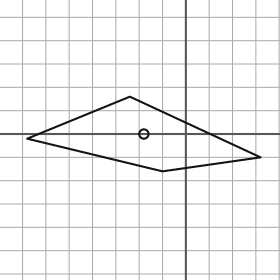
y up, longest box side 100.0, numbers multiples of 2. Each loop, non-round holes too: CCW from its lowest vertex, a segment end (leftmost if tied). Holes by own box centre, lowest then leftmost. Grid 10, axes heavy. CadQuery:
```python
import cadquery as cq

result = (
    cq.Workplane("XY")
    .moveTo(-10.0, -16.0)
    .lineTo(32.0, -10.0)
    .lineTo(-24.0, 16.0)
    .lineTo(-68.0, -2.0)
    .close()
    .moveTo(-18.0, 0.0)
    .circle(2.0)
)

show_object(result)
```